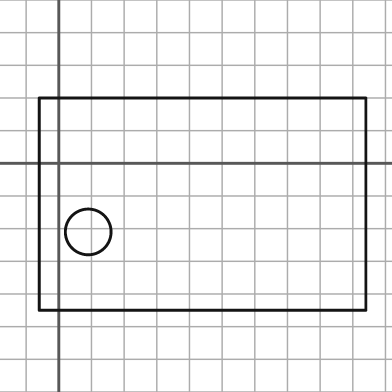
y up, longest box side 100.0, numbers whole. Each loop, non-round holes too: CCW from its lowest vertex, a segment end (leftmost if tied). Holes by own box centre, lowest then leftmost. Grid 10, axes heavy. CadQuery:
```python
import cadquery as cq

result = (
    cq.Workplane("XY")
    .moveTo(-6.0, -45.0)
    .lineTo(94.0, -45.0)
    .lineTo(94.0, 20.0)
    .lineTo(-6.0, 20.0)
    .close()
    .moveTo(9.0, -21.0)
    .circle(7.0)
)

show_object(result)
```